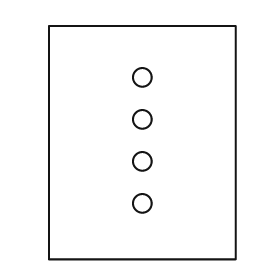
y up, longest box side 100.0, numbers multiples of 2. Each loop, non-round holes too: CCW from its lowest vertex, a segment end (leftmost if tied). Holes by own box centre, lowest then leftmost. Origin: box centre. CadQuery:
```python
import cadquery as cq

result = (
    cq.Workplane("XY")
    .moveTo(-40.0, -50.0)
    .lineTo(40.0, -50.0)
    .lineTo(40.0, 50.0)
    .lineTo(-40.0, 50.0)
    .close()
    .moveTo(0.0, -26.0)
    .circle(4.0)
    .moveTo(0.0, -8.0)
    .circle(4.0)
    .moveTo(0.0, 10.0)
    .circle(4.0)
    .moveTo(0.0, 28.0)
    .circle(4.0)
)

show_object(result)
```